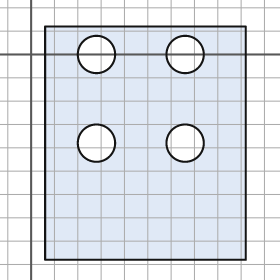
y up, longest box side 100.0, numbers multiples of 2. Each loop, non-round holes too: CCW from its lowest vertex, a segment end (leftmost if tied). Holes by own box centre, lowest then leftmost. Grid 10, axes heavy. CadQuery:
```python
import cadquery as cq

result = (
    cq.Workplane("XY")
    .moveTo(6.0, -88.0)
    .lineTo(92.0, -88.0)
    .lineTo(92.0, 12.0)
    .lineTo(6.0, 12.0)
    .close()
    .moveTo(28.0, -38.0)
    .circle(8.0)
    .moveTo(66.0, -38.0)
    .circle(8.0)
    .moveTo(28.0, 0.0)
    .circle(8.0)
    .moveTo(66.0, 0.0)
    .circle(8.0)
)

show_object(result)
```